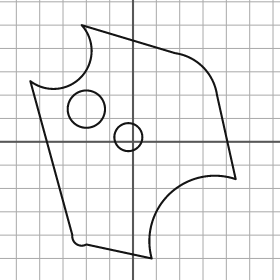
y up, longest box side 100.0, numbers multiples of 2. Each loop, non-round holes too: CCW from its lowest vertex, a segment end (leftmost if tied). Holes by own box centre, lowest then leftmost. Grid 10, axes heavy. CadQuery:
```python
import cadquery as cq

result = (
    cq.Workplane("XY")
    .moveTo(8.0, -50.0)
    .threePointArc((16.0, -22.0), (44.0, -16.0))
    .lineTo(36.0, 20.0)
    .threePointArc((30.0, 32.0), (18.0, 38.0))
    .lineTo(-22.0, 50.0)
    .threePointArc((-22.0, 28.0), (-44.0, 26.0))
    .lineTo(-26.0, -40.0)
    .threePointArc((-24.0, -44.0), (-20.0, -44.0))
    .close()
    .moveTo(-2.0, 2.0)
    .circle(6.0)
    .moveTo(-20.0, 14.0)
    .circle(8.0)
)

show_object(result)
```